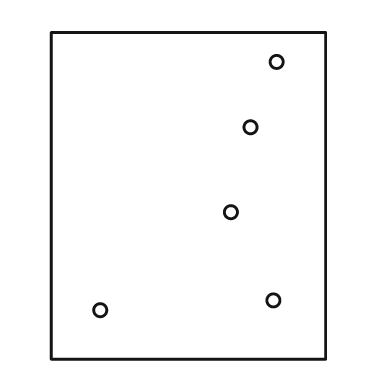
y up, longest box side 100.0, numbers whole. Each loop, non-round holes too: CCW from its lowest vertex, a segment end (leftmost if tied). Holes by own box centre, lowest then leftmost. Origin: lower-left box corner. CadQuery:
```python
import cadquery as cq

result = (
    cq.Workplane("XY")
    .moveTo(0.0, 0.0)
    .lineTo(84.0, 0.0)
    .lineTo(84.0, 100.0)
    .lineTo(0.0, 100.0)
    .close()
    .moveTo(15.0, 15.0)
    .circle(2.0)
    .moveTo(68.0, 18.0)
    .circle(2.0)
    .moveTo(55.0, 45.0)
    .circle(2.0)
    .moveTo(61.0, 71.0)
    .circle(2.0)
    .moveTo(69.0, 91.0)
    .circle(2.0)
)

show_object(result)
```